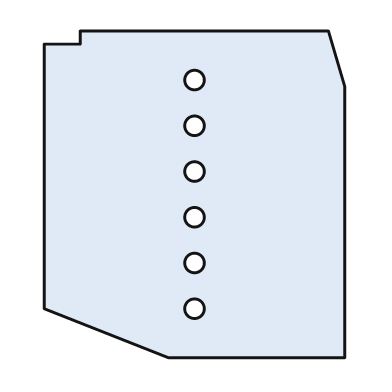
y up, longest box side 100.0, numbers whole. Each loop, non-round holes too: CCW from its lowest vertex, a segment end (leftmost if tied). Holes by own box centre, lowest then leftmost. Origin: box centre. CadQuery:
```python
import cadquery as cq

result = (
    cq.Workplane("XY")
    .moveTo(-8.0, -50.0)
    .lineTo(46.0, -50.0)
    .lineTo(46.0, 33.0)
    .lineTo(41.0, 50.0)
    .lineTo(-35.0, 50.0)
    .lineTo(-35.0, 46.0)
    .lineTo(-46.0, 46.0)
    .lineTo(-46.0, -35.0)
    .close()
    .moveTo(0.0, -35.0)
    .circle(3.0)
    .moveTo(0.0, -21.0)
    .circle(3.0)
    .moveTo(0.0, -7.0)
    .circle(3.0)
    .moveTo(0.0, 7.0)
    .circle(3.0)
    .moveTo(0.0, 21.0)
    .circle(3.0)
    .moveTo(0.0, 35.0)
    .circle(3.0)
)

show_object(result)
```